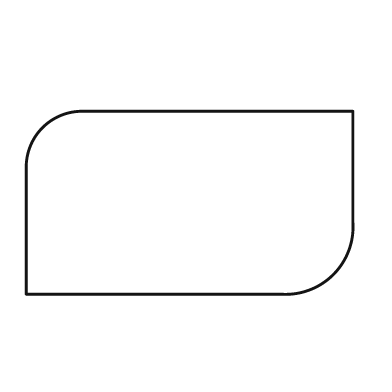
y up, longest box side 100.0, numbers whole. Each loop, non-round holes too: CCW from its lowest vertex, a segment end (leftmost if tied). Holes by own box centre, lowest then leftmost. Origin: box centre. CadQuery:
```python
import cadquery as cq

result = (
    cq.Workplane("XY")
    .moveTo(-50.0, -28.0)
    .lineTo(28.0, -28.0)
    .threePointArc((44.0, -22.0), (50.0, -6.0))
    .lineTo(50.0, 28.0)
    .lineTo(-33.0, 28.0)
    .threePointArc((-45.0, 23.0), (-50.0, 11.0))
    .close()
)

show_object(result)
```